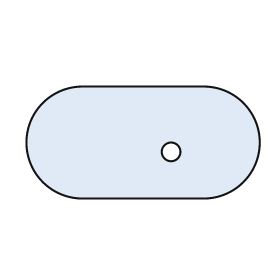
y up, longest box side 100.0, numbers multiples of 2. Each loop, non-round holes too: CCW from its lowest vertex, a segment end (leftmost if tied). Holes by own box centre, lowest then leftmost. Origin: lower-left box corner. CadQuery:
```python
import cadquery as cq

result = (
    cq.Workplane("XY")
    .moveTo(24.0, 0.0)
    .lineTo(76.0, 0.0)
    .threePointArc((100.0, 24.0), (76.0, 48.0))
    .lineTo(24.0, 48.0)
    .threePointArc((0.0, 24.0), (24.0, 0.0))
    .close()
    .moveTo(62.0, 20.0)
    .circle(4.0)
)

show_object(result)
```